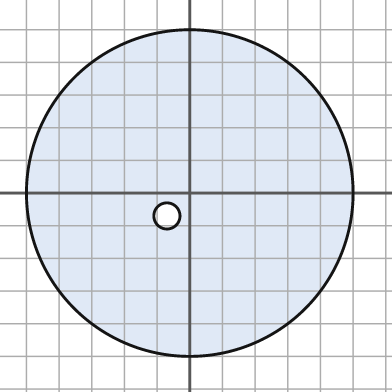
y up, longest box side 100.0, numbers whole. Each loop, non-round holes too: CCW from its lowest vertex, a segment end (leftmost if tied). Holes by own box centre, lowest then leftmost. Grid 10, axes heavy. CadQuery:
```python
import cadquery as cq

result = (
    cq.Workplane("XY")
    .moveTo(0.0, 0.0)
    .circle(50.0)
    .moveTo(-7.0, -7.0)
    .circle(4.0)
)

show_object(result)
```